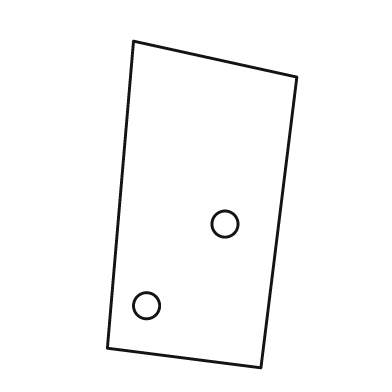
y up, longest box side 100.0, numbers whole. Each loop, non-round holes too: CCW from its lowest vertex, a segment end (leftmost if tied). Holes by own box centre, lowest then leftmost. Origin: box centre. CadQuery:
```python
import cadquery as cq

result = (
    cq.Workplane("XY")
    .moveTo(18.0, -50.0)
    .lineTo(29.0, 39.0)
    .lineTo(-21.0, 50.0)
    .lineTo(-29.0, -44.0)
    .close()
    .moveTo(-17.0, -31.0)
    .circle(4.0)
    .moveTo(7.0, -6.0)
    .circle(4.0)
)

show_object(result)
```